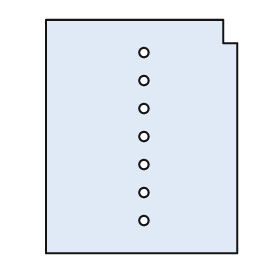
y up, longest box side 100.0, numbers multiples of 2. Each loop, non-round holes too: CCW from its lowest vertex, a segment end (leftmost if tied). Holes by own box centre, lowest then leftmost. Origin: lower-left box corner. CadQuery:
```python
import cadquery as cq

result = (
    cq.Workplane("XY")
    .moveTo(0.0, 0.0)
    .lineTo(82.0, 0.0)
    .lineTo(82.0, 90.0)
    .lineTo(76.0, 90.0)
    .lineTo(76.0, 100.0)
    .lineTo(0.0, 100.0)
    .close()
    .moveTo(42.0, 14.0)
    .circle(2.0)
    .moveTo(42.0, 26.0)
    .circle(2.0)
    .moveTo(42.0, 38.0)
    .circle(2.0)
    .moveTo(42.0, 50.0)
    .circle(2.0)
    .moveTo(42.0, 62.0)
    .circle(2.0)
    .moveTo(42.0, 74.0)
    .circle(2.0)
    .moveTo(42.0, 86.0)
    .circle(2.0)
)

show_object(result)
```